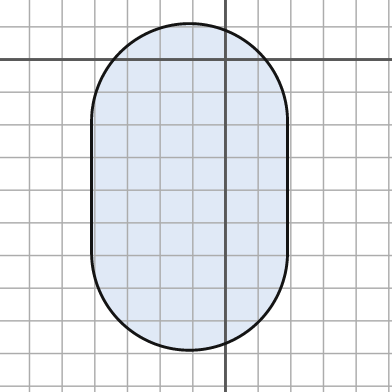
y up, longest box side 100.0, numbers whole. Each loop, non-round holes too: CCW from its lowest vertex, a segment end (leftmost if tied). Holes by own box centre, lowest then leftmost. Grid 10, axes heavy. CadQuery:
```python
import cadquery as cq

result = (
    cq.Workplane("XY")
    .moveTo(-41.0, -59.0)
    .threePointArc((-11.0, -89.0), (19.0, -59.0))
    .lineTo(19.0, -19.0)
    .threePointArc((-11.0, 11.0), (-41.0, -19.0))
    .close()
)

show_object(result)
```